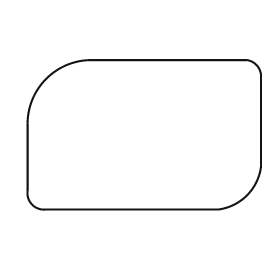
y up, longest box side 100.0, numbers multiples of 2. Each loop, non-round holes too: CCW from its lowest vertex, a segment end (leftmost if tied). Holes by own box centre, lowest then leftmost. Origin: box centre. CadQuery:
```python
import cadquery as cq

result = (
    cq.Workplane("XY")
    .moveTo(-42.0, -32.0)
    .lineTo(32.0, -32.0)
    .threePointArc((44.0, -26.0), (50.0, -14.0))
    .lineTo(50.0, 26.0)
    .threePointArc((48.0, 30.0), (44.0, 32.0))
    .lineTo(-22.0, 32.0)
    .threePointArc((-42.0, 24.0), (-50.0, 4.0))
    .lineTo(-50.0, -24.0)
    .threePointArc((-48.0, -30.0), (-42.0, -32.0))
    .close()
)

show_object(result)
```